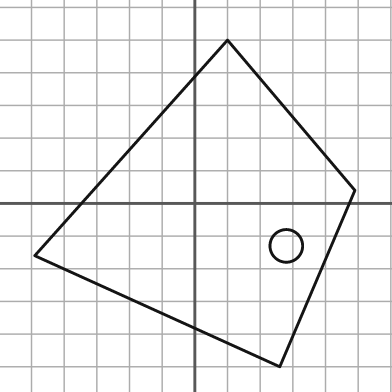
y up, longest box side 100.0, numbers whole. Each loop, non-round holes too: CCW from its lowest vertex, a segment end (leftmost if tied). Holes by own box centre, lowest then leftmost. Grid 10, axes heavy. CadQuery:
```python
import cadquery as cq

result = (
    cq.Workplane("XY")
    .moveTo(26.0, -50.0)
    .lineTo(49.0, 4.0)
    .lineTo(10.0, 50.0)
    .lineTo(-49.0, -16.0)
    .close()
    .moveTo(28.0, -13.0)
    .circle(5.0)
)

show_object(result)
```